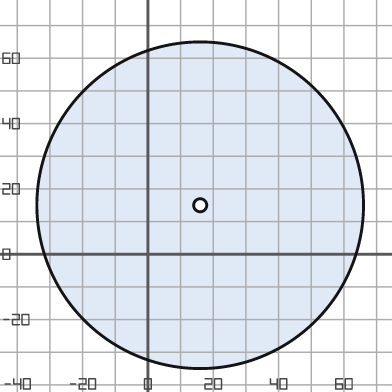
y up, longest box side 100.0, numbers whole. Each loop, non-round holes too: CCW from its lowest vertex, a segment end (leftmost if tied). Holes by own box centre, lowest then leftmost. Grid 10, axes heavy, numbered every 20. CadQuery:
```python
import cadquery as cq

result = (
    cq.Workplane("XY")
    .moveTo(16.0, 15.0)
    .circle(50.0)
    .moveTo(16.0, 15.0)
    .circle(2.0)
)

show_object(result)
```